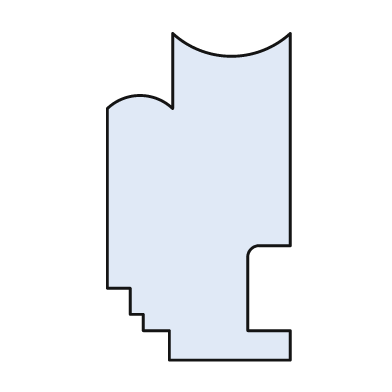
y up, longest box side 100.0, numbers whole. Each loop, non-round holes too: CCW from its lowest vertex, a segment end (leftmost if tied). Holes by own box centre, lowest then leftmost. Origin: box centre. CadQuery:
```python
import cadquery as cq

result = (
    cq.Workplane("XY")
    .moveTo(-9.0, -50.0)
    .lineTo(28.0, -50.0)
    .lineTo(28.0, -41.0)
    .lineTo(15.0, -41.0)
    .lineTo(15.0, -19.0)
    .threePointArc((16.0, -16.0), (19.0, -15.0))
    .lineTo(28.0, -15.0)
    .lineTo(28.0, 50.0)
    .threePointArc((10.0, 43.0), (-8.0, 50.0))
    .lineTo(-8.0, 27.0)
    .threePointArc((-18.0, 31.0), (-28.0, 27.0))
    .lineTo(-28.0, -28.0)
    .lineTo(-21.0, -28.0)
    .lineTo(-21.0, -36.0)
    .lineTo(-17.0, -36.0)
    .lineTo(-17.0, -41.0)
    .lineTo(-9.0, -41.0)
    .close()
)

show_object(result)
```